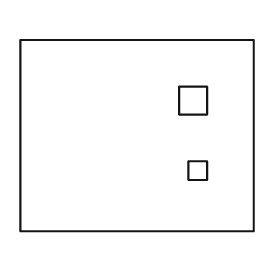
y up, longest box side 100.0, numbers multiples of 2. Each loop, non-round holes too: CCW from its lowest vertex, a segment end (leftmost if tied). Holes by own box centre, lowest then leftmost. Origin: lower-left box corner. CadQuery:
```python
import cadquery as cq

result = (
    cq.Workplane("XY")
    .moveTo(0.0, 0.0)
    .lineTo(100.0, 0.0)
    .lineTo(100.0, 82.0)
    .lineTo(0.0, 82.0)
    .close()
    .moveTo(72.0, 22.0)
    .lineTo(80.0, 22.0)
    .lineTo(80.0, 30.0)
    .lineTo(72.0, 30.0)
    .close()
    .moveTo(68.0, 50.0)
    .lineTo(80.0, 50.0)
    .lineTo(80.0, 62.0)
    .lineTo(68.0, 62.0)
    .close()
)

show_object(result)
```